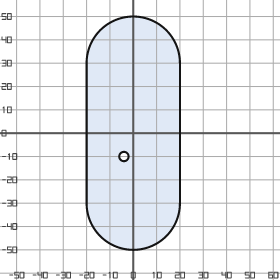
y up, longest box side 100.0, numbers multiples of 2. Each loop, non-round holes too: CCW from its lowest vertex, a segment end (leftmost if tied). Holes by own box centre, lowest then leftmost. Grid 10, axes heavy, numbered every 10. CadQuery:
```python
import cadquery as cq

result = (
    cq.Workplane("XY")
    .moveTo(-20.0, -30.0)
    .threePointArc((0.0, -50.0), (20.0, -30.0))
    .lineTo(20.0, 30.0)
    .threePointArc((0.0, 50.0), (-20.0, 30.0))
    .close()
    .moveTo(-4.0, -10.0)
    .circle(2.0)
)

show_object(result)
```